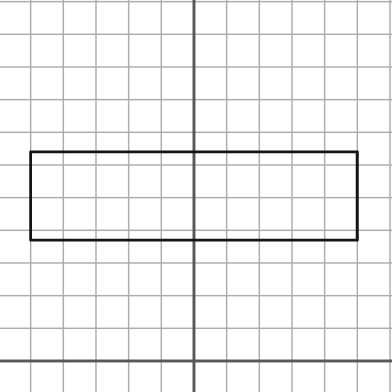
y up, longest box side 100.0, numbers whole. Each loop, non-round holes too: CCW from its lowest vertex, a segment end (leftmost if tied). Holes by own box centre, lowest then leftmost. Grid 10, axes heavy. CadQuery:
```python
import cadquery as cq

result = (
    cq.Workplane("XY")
    .moveTo(-50.0, 37.0)
    .lineTo(50.0, 37.0)
    .lineTo(50.0, 64.0)
    .lineTo(-50.0, 64.0)
    .close()
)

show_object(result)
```